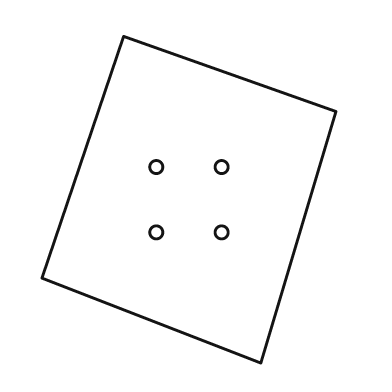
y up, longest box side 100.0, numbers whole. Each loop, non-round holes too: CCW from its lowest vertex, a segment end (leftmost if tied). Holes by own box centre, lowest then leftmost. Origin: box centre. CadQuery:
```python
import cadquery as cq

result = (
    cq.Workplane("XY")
    .moveTo(22.0, -50.0)
    .lineTo(45.0, 27.0)
    .lineTo(-20.0, 50.0)
    .lineTo(-45.0, -24.0)
    .close()
    .moveTo(-10.0, -10.0)
    .circle(2.0)
    .moveTo(10.0, -10.0)
    .circle(2.0)
    .moveTo(-10.0, 10.0)
    .circle(2.0)
    .moveTo(10.0, 10.0)
    .circle(2.0)
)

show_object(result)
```